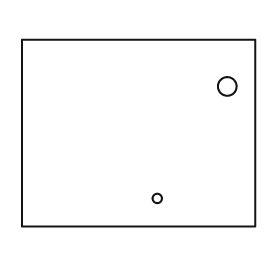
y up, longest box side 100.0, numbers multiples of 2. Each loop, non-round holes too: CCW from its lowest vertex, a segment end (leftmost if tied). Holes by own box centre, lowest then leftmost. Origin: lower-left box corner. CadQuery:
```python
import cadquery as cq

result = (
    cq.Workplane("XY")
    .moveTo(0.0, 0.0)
    .lineTo(100.0, 0.0)
    .lineTo(100.0, 80.0)
    .lineTo(0.0, 80.0)
    .close()
    .moveTo(58.0, 12.0)
    .circle(2.0)
    .moveTo(88.0, 60.0)
    .circle(4.0)
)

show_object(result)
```